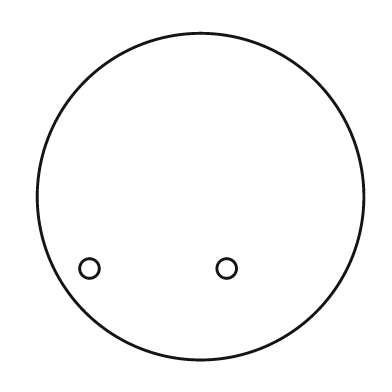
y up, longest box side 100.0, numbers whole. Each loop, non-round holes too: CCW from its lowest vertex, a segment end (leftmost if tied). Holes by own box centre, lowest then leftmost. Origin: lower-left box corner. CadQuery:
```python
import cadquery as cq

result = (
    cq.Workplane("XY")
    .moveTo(50.0, 50.0)
    .circle(50.0)
    .moveTo(16.0, 28.0)
    .circle(3.0)
    .moveTo(58.0, 28.0)
    .circle(3.0)
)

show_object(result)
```